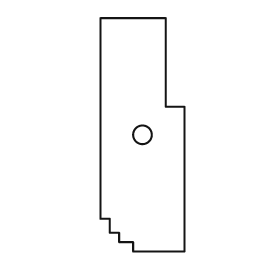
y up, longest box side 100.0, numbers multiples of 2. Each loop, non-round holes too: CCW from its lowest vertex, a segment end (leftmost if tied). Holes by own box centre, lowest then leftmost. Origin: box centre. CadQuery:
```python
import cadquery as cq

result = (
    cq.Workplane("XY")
    .moveTo(-4.0, -50.0)
    .lineTo(18.0, -50.0)
    .lineTo(18.0, 12.0)
    .lineTo(10.0, 12.0)
    .lineTo(10.0, 50.0)
    .lineTo(-18.0, 50.0)
    .lineTo(-18.0, -36.0)
    .lineTo(-14.0, -36.0)
    .lineTo(-14.0, -42.0)
    .lineTo(-10.0, -42.0)
    .lineTo(-10.0, -46.0)
    .lineTo(-4.0, -46.0)
    .close()
    .moveTo(0.0, 0.0)
    .circle(4.0)
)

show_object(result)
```